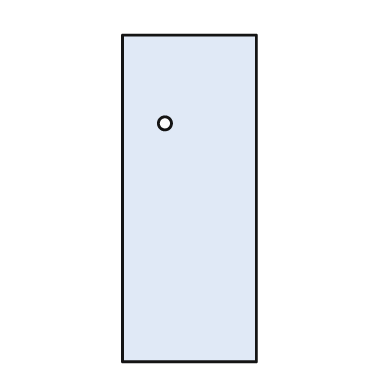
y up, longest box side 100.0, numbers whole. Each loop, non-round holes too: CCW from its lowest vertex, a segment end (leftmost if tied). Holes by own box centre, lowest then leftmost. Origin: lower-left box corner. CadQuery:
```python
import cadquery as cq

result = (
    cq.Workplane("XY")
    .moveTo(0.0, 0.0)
    .lineTo(41.0, 0.0)
    .lineTo(41.0, 100.0)
    .lineTo(0.0, 100.0)
    .close()
    .moveTo(13.0, 73.0)
    .circle(2.0)
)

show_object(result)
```